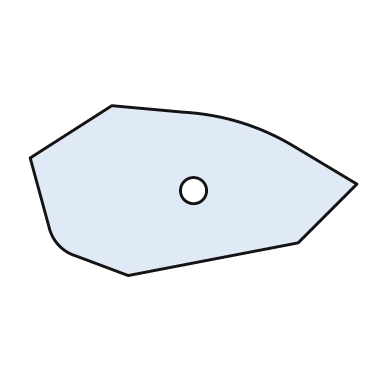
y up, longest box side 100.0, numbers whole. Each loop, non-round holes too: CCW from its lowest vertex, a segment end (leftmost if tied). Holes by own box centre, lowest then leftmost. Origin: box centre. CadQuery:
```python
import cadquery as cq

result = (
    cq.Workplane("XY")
    .moveTo(-20.0, -26.0)
    .lineTo(32.0, -16.0)
    .lineTo(50.0, 2.0)
    .lineTo(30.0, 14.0)
    .threePointArc((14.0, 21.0), (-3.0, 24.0))
    .lineTo(-25.0, 26.0)
    .lineTo(-50.0, 10.0)
    .lineTo(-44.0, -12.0)
    .threePointArc((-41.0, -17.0), (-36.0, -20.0))
    .close()
    .moveTo(0.0, 0.0)
    .circle(4.0)
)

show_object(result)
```